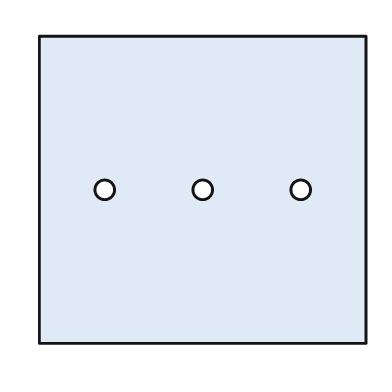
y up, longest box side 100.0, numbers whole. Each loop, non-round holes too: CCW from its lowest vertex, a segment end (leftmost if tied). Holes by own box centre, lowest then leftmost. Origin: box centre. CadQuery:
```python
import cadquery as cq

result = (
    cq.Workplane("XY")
    .moveTo(-50.0, -47.0)
    .lineTo(50.0, -47.0)
    .lineTo(50.0, 47.0)
    .lineTo(-50.0, 47.0)
    .close()
    .moveTo(-30.0, 0.0)
    .circle(3.0)
    .moveTo(0.0, 0.0)
    .circle(3.0)
    .moveTo(30.0, 0.0)
    .circle(3.0)
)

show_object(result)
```